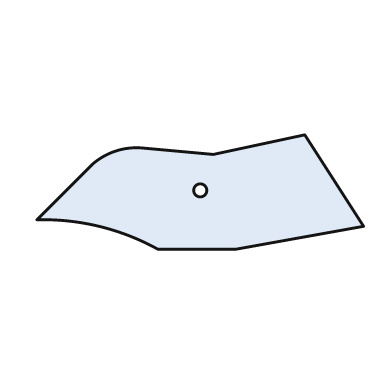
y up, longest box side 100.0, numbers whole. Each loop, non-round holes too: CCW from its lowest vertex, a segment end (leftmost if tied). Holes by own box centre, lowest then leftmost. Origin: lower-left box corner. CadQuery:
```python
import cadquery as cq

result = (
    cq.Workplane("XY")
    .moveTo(37.0, 0.0)
    .lineTo(61.0, 0.0)
    .lineTo(100.0, 7.0)
    .lineTo(82.0, 35.0)
    .lineTo(54.0, 29.0)
    .lineTo(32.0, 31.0)
    .threePointArc((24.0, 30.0), (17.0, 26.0))
    .lineTo(0.0, 9.0)
    .threePointArc((19.0, 7.0), (37.0, 0.0))
    .close()
    .moveTo(50.0, 18.0)
    .circle(2.0)
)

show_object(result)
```